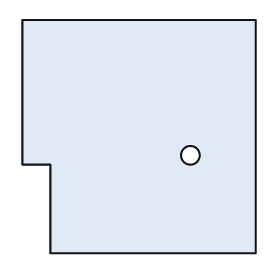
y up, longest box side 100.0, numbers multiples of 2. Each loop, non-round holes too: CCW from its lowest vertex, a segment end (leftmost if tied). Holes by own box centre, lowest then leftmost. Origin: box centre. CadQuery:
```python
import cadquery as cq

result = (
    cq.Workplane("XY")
    .moveTo(-38.0, -50.0)
    .lineTo(50.0, -50.0)
    .lineTo(50.0, 50.0)
    .lineTo(-50.0, 50.0)
    .lineTo(-50.0, -12.0)
    .lineTo(-38.0, -12.0)
    .close()
    .moveTo(22.0, -8.0)
    .circle(4.0)
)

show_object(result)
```